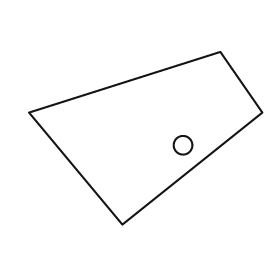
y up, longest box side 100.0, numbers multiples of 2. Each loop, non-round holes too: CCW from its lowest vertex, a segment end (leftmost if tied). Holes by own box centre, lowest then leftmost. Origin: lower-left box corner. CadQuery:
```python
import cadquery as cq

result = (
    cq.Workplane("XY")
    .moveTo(40.0, 0.0)
    .lineTo(100.0, 48.0)
    .lineTo(82.0, 74.0)
    .lineTo(0.0, 48.0)
    .close()
    .moveTo(66.0, 34.0)
    .circle(4.0)
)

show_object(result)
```